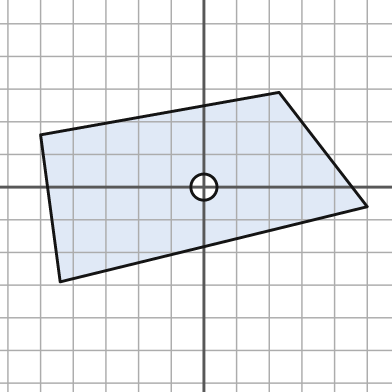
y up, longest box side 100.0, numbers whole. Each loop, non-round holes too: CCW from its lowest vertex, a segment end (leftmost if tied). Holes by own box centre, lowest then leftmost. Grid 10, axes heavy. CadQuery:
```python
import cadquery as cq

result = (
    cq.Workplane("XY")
    .moveTo(-44.0, -29.0)
    .lineTo(50.0, -6.0)
    .lineTo(23.0, 29.0)
    .lineTo(-50.0, 16.0)
    .close()
    .moveTo(0.0, 0.0)
    .circle(4.0)
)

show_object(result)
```